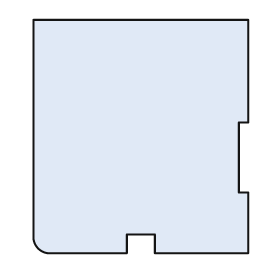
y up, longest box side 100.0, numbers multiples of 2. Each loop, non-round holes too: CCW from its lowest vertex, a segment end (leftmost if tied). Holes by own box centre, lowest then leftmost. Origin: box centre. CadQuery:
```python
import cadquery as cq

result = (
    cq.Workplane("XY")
    .moveTo(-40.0, -50.0)
    .lineTo(-6.0, -50.0)
    .lineTo(-6.0, -42.0)
    .lineTo(6.0, -42.0)
    .lineTo(6.0, -50.0)
    .lineTo(46.0, -50.0)
    .lineTo(46.0, -24.0)
    .lineTo(42.0, -24.0)
    .lineTo(42.0, 6.0)
    .lineTo(46.0, 6.0)
    .lineTo(46.0, 50.0)
    .lineTo(-46.0, 50.0)
    .lineTo(-46.0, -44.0)
    .threePointArc((-44.0, -48.0), (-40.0, -50.0))
    .close()
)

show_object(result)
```